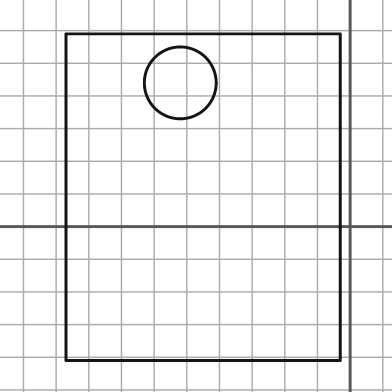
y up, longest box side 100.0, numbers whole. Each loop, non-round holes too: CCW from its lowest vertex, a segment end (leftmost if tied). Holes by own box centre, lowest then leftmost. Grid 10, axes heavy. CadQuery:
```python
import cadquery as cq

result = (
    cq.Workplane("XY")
    .moveTo(-87.0, -41.0)
    .lineTo(-3.0, -41.0)
    .lineTo(-3.0, 59.0)
    .lineTo(-87.0, 59.0)
    .close()
    .moveTo(-52.0, 44.0)
    .circle(11.0)
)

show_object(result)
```